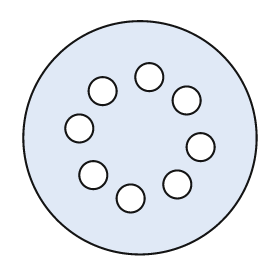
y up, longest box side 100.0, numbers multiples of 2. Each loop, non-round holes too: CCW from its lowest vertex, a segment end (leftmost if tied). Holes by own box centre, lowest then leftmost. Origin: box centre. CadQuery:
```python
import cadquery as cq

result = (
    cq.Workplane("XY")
    .moveTo(0.0, 0.0)
    .circle(50.0)
    .moveTo(-4.0, -26.0)
    .circle(6.0)
    .moveTo(16.0, -20.0)
    .circle(6.0)
    .moveTo(-20.0, -16.0)
    .circle(6.0)
    .moveTo(26.0, -4.0)
    .circle(6.0)
    .moveTo(-26.0, 4.0)
    .circle(6.0)
    .moveTo(20.0, 16.0)
    .circle(6.0)
    .moveTo(-16.0, 20.0)
    .circle(6.0)
    .moveTo(4.0, 26.0)
    .circle(6.0)
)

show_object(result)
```